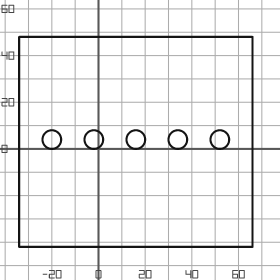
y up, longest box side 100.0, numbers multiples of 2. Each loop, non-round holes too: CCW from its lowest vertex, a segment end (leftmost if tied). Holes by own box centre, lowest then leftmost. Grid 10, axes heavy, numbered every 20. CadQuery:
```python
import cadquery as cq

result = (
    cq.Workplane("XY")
    .moveTo(-34.0, -42.0)
    .lineTo(66.0, -42.0)
    .lineTo(66.0, 48.0)
    .lineTo(-34.0, 48.0)
    .close()
    .moveTo(-20.0, 4.0)
    .circle(4.0)
    .moveTo(-2.0, 4.0)
    .circle(4.0)
    .moveTo(16.0, 4.0)
    .circle(4.0)
    .moveTo(34.0, 4.0)
    .circle(4.0)
    .moveTo(52.0, 4.0)
    .circle(4.0)
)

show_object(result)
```